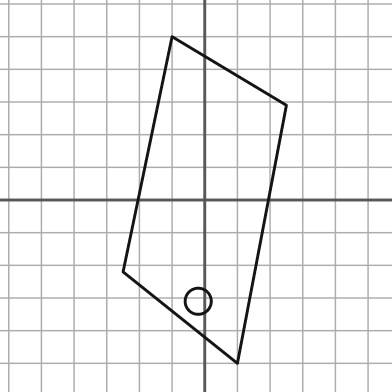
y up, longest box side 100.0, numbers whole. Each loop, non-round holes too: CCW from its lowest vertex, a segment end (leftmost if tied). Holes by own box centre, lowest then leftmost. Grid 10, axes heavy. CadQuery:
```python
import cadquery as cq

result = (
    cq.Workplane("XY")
    .moveTo(10.0, -50.0)
    .lineTo(25.0, 29.0)
    .lineTo(-10.0, 50.0)
    .lineTo(-25.0, -22.0)
    .close()
    .moveTo(-2.0, -31.0)
    .circle(4.0)
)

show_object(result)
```